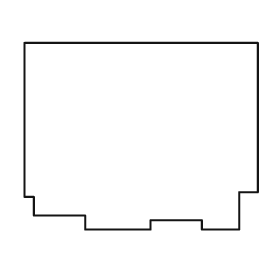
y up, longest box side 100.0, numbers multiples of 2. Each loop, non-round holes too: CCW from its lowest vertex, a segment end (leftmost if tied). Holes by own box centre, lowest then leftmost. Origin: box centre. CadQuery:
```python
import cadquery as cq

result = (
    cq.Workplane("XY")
    .moveTo(-24.0, -40.0)
    .lineTo(4.0, -40.0)
    .lineTo(4.0, -36.0)
    .lineTo(26.0, -36.0)
    .lineTo(26.0, -40.0)
    .lineTo(42.0, -40.0)
    .lineTo(42.0, -24.0)
    .lineTo(50.0, -24.0)
    .lineTo(50.0, 40.0)
    .lineTo(-50.0, 40.0)
    .lineTo(-50.0, -26.0)
    .lineTo(-46.0, -26.0)
    .lineTo(-46.0, -34.0)
    .lineTo(-24.0, -34.0)
    .close()
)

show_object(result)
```